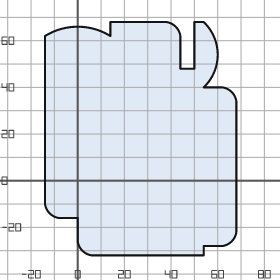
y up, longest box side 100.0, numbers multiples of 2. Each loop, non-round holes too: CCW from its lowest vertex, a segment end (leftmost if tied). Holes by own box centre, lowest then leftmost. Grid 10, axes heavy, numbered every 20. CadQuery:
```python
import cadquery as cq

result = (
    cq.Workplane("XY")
    .moveTo(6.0, -32.0)
    .lineTo(54.0, -32.0)
    .lineTo(54.0, -28.0)
    .lineTo(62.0, -28.0)
    .threePointArc((66.0, -26.0), (68.0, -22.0))
    .lineTo(68.0, 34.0)
    .threePointArc((66.0, 38.0), (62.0, 40.0))
    .lineTo(54.0, 40.0)
    .threePointArc((60.0, 54.0), (54.0, 68.0))
    .lineTo(50.0, 68.0)
    .lineTo(50.0, 48.0)
    .lineTo(44.0, 48.0)
    .lineTo(44.0, 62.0)
    .threePointArc((42.0, 66.0), (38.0, 68.0))
    .lineTo(14.0, 68.0)
    .lineTo(14.0, 62.0)
    .threePointArc((0.0, 66.0), (-14.0, 62.0))
    .lineTo(-14.0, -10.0)
    .threePointArc((-12.0, -14.0), (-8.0, -16.0))
    .lineTo(0.0, -16.0)
    .lineTo(0.0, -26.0)
    .threePointArc((2.0, -30.0), (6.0, -32.0))
    .close()
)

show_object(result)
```